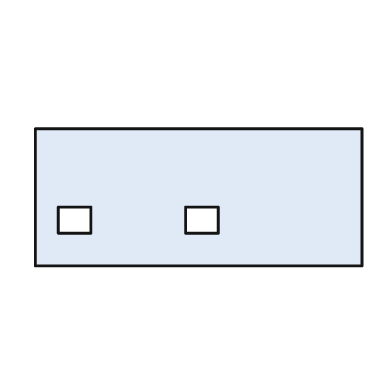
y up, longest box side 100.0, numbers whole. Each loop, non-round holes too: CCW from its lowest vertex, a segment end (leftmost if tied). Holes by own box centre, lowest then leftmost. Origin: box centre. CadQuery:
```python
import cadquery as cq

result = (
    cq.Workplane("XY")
    .moveTo(-50.0, -21.0)
    .lineTo(50.0, -21.0)
    .lineTo(50.0, 21.0)
    .lineTo(-50.0, 21.0)
    .close()
    .moveTo(-43.0, -11.0)
    .lineTo(-33.0, -11.0)
    .lineTo(-33.0, -3.0)
    .lineTo(-43.0, -3.0)
    .close()
    .moveTo(-4.0, -11.0)
    .lineTo(6.0, -11.0)
    .lineTo(6.0, -3.0)
    .lineTo(-4.0, -3.0)
    .close()
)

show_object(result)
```